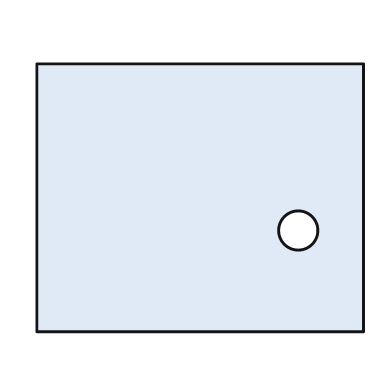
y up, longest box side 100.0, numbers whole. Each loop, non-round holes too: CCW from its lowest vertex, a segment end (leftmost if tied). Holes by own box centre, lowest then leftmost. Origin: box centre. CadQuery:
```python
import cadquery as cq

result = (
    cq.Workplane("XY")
    .moveTo(-50.0, -41.0)
    .lineTo(50.0, -41.0)
    .lineTo(50.0, 41.0)
    .lineTo(-50.0, 41.0)
    .close()
    .moveTo(30.0, -10.0)
    .circle(6.0)
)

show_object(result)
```